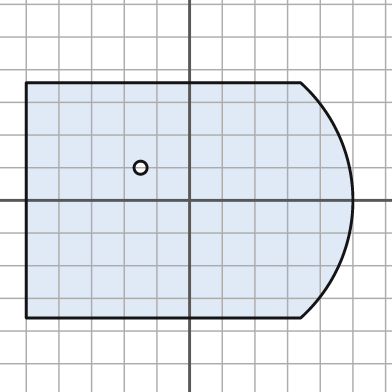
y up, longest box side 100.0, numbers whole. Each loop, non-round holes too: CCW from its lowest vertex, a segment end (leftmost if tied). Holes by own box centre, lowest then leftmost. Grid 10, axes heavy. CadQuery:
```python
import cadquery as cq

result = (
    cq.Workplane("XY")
    .moveTo(-50.0, -36.0)
    .lineTo(34.0, -36.0)
    .threePointArc((50.0, 0.0), (34.0, 36.0))
    .lineTo(-50.0, 36.0)
    .close()
    .moveTo(-15.0, 10.0)
    .circle(2.0)
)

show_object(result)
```